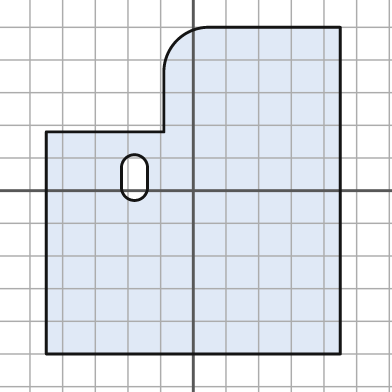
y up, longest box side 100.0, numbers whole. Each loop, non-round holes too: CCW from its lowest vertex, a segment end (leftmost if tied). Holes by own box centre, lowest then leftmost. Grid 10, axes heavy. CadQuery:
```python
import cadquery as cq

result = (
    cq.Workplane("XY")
    .moveTo(-45.0, -50.0)
    .lineTo(45.0, -50.0)
    .lineTo(45.0, 50.0)
    .lineTo(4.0, 50.0)
    .threePointArc((-5.0, 46.0), (-9.0, 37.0))
    .lineTo(-9.0, 18.0)
    .lineTo(-45.0, 18.0)
    .close()
    .moveTo(-22.0, 1.0)
    .threePointArc((-18.0, -3.0), (-14.0, 1.0))
    .lineTo(-14.0, 7.0)
    .threePointArc((-18.0, 11.0), (-22.0, 7.0))
    .close()
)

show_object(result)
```